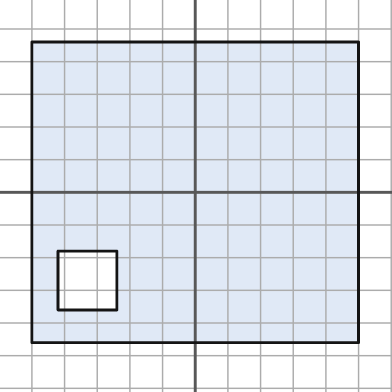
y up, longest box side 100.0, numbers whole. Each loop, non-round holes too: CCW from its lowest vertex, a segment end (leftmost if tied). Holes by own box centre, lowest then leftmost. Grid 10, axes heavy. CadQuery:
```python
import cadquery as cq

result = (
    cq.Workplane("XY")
    .moveTo(-50.0, -46.0)
    .lineTo(50.0, -46.0)
    .lineTo(50.0, 46.0)
    .lineTo(-50.0, 46.0)
    .close()
    .moveTo(-42.0, -36.0)
    .lineTo(-24.0, -36.0)
    .lineTo(-24.0, -18.0)
    .lineTo(-42.0, -18.0)
    .close()
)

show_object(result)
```